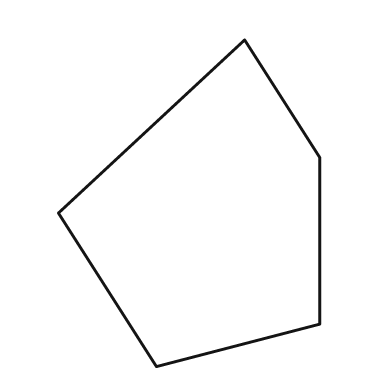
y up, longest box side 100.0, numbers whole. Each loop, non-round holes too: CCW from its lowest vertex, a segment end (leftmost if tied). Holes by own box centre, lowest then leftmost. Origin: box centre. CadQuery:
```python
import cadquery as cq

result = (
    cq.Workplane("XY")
    .moveTo(-10.0, -50.0)
    .lineTo(40.0, -37.0)
    .lineTo(40.0, 14.0)
    .lineTo(17.0, 50.0)
    .lineTo(-40.0, -3.0)
    .close()
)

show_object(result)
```